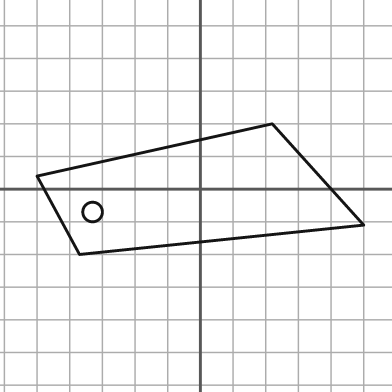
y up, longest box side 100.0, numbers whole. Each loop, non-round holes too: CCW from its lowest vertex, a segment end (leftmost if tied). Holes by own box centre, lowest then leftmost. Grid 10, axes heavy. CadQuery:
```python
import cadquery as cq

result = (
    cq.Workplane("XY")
    .moveTo(-37.0, -20.0)
    .lineTo(50.0, -11.0)
    .lineTo(22.0, 20.0)
    .lineTo(-50.0, 4.0)
    .close()
    .moveTo(-33.0, -7.0)
    .circle(3.0)
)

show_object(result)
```